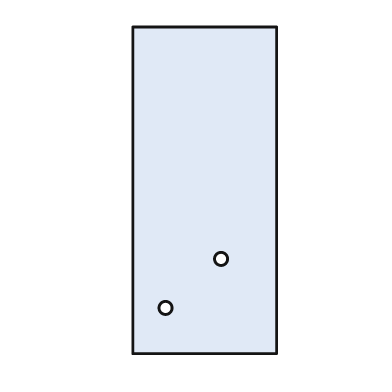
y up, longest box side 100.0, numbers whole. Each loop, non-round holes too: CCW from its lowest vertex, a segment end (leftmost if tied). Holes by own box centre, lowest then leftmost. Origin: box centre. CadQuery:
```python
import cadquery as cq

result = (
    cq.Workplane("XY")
    .moveTo(-22.0, -50.0)
    .lineTo(22.0, -50.0)
    .lineTo(22.0, 50.0)
    .lineTo(-22.0, 50.0)
    .close()
    .moveTo(-12.0, -36.0)
    .circle(2.0)
    .moveTo(5.0, -21.0)
    .circle(2.0)
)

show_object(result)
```